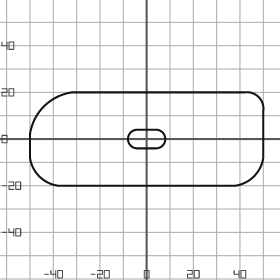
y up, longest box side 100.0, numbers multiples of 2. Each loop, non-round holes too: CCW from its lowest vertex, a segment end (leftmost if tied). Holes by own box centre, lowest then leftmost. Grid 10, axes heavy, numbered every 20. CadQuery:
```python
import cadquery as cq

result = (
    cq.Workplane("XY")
    .moveTo(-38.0, -20.0)
    .lineTo(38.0, -20.0)
    .threePointArc((46.0, -16.0), (50.0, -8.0))
    .lineTo(50.0, 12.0)
    .threePointArc((48.0, 18.0), (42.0, 20.0))
    .lineTo(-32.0, 20.0)
    .threePointArc((-44.0, 14.0), (-50.0, 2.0))
    .lineTo(-50.0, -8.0)
    .threePointArc((-46.0, -16.0), (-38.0, -20.0))
    .close()
    .moveTo(-4.0, -4.0)
    .lineTo(4.0, -4.0)
    .threePointArc((8.0, 0.0), (4.0, 4.0))
    .lineTo(-4.0, 4.0)
    .threePointArc((-8.0, 0.0), (-4.0, -4.0))
    .close()
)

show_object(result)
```